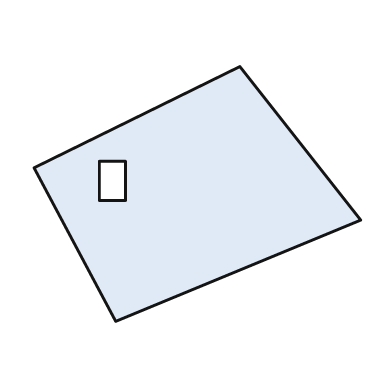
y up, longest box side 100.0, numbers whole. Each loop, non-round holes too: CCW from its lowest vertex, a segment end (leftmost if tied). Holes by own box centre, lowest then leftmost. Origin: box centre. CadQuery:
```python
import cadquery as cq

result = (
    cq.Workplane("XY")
    .moveTo(-25.0, -39.0)
    .lineTo(50.0, -8.0)
    .lineTo(13.0, 39.0)
    .lineTo(-50.0, 8.0)
    .close()
    .moveTo(-30.0, -2.0)
    .lineTo(-22.0, -2.0)
    .lineTo(-22.0, 10.0)
    .lineTo(-30.0, 10.0)
    .close()
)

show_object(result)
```